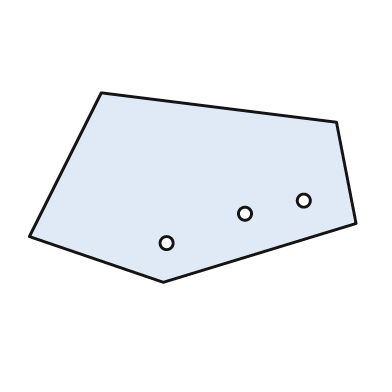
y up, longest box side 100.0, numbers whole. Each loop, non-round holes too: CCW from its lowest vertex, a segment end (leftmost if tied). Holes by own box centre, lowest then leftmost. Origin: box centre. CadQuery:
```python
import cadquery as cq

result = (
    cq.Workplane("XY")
    .moveTo(-9.0, -29.0)
    .lineTo(50.0, -11.0)
    .lineTo(44.0, 20.0)
    .lineTo(-28.0, 29.0)
    .lineTo(-50.0, -15.0)
    .close()
    .moveTo(-8.0, -17.0)
    .circle(2.0)
    .moveTo(16.0, -8.0)
    .circle(2.0)
    .moveTo(34.0, -4.0)
    .circle(2.0)
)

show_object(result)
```